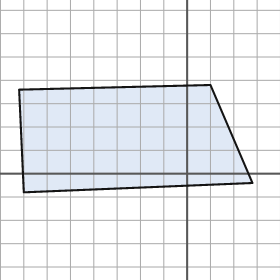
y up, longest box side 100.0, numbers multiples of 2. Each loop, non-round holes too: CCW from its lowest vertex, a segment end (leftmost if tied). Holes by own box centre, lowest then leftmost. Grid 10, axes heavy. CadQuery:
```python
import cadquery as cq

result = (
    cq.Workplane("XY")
    .moveTo(-70.0, -8.0)
    .lineTo(28.0, -4.0)
    .lineTo(10.0, 38.0)
    .lineTo(-72.0, 36.0)
    .close()
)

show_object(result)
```